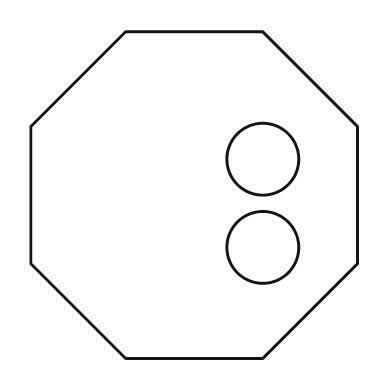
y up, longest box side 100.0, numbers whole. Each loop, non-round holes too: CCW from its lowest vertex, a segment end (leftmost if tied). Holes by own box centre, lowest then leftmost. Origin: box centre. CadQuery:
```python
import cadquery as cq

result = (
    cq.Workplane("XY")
    .moveTo(-21.0, -50.0)
    .lineTo(21.0, -50.0)
    .lineTo(50.0, -21.0)
    .lineTo(50.0, 21.0)
    .lineTo(21.0, 50.0)
    .lineTo(-21.0, 50.0)
    .lineTo(-50.0, 21.0)
    .lineTo(-50.0, -21.0)
    .close()
    .moveTo(21.0, -16.0)
    .circle(11.0)
    .moveTo(21.0, 11.0)
    .circle(11.0)
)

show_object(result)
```